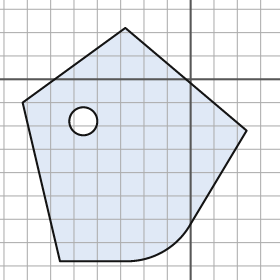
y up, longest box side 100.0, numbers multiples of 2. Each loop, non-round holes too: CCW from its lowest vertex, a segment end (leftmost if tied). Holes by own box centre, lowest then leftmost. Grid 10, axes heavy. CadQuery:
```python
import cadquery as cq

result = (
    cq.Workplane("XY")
    .moveTo(-56.0, -78.0)
    .lineTo(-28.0, -78.0)
    .threePointArc((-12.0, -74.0), (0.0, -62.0))
    .lineTo(24.0, -22.0)
    .lineTo(-28.0, 22.0)
    .lineTo(-72.0, -10.0)
    .close()
    .moveTo(-46.0, -18.0)
    .circle(6.0)
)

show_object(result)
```